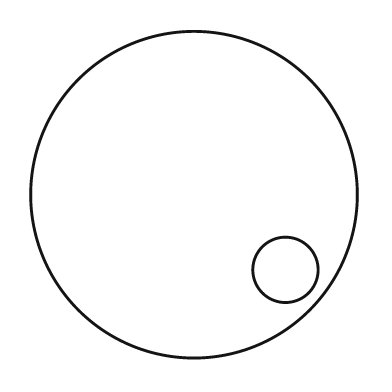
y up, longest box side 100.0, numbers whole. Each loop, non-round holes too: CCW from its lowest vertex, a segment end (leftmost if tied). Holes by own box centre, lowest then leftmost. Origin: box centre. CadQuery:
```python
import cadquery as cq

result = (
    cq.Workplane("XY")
    .moveTo(0.0, 0.0)
    .circle(50.0)
    .moveTo(28.0, -23.0)
    .circle(10.0)
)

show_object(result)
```